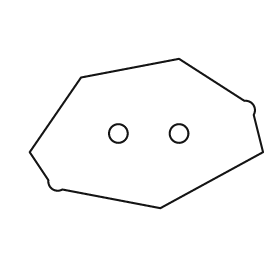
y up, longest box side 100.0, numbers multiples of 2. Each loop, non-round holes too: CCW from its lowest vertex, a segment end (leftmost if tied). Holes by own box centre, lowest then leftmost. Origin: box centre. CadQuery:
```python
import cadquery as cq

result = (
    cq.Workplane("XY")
    .moveTo(6.0, -32.0)
    .lineTo(50.0, -8.0)
    .lineTo(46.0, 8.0)
    .threePointArc((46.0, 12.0), (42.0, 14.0))
    .lineTo(14.0, 32.0)
    .lineTo(-28.0, 24.0)
    .lineTo(-50.0, -8.0)
    .lineTo(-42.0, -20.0)
    .threePointArc((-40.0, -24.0), (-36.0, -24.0))
    .close()
    .moveTo(-12.0, 0.0)
    .circle(4.0)
    .moveTo(14.0, 0.0)
    .circle(4.0)
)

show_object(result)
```